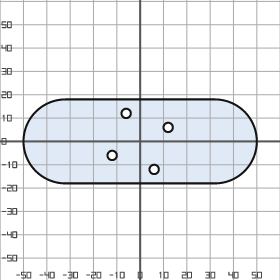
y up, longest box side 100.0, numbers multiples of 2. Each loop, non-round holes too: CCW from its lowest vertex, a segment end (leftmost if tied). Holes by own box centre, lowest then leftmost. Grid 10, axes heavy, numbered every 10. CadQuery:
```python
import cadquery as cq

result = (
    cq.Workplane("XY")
    .moveTo(-32.0, -18.0)
    .lineTo(32.0, -18.0)
    .threePointArc((50.0, 0.0), (32.0, 18.0))
    .lineTo(-32.0, 18.0)
    .threePointArc((-50.0, 0.0), (-32.0, -18.0))
    .close()
    .moveTo(6.0, -12.0)
    .circle(2.0)
    .moveTo(-12.0, -6.0)
    .circle(2.0)
    .moveTo(12.0, 6.0)
    .circle(2.0)
    .moveTo(-6.0, 12.0)
    .circle(2.0)
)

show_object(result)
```